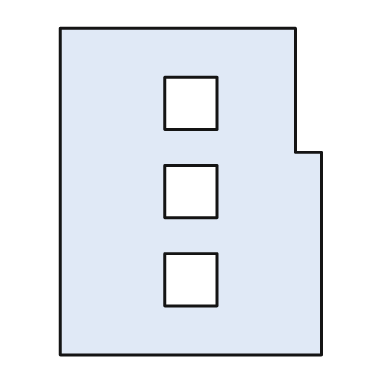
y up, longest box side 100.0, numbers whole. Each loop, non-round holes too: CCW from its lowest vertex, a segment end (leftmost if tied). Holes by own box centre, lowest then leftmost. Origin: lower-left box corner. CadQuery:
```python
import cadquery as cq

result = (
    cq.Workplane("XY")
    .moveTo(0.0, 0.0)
    .lineTo(80.0, 0.0)
    .lineTo(80.0, 62.0)
    .lineTo(72.0, 62.0)
    .lineTo(72.0, 100.0)
    .lineTo(0.0, 100.0)
    .close()
    .moveTo(32.0, 15.0)
    .lineTo(48.0, 15.0)
    .lineTo(48.0, 31.0)
    .lineTo(32.0, 31.0)
    .close()
    .moveTo(32.0, 42.0)
    .lineTo(48.0, 42.0)
    .lineTo(48.0, 58.0)
    .lineTo(32.0, 58.0)
    .close()
    .moveTo(32.0, 69.0)
    .lineTo(48.0, 69.0)
    .lineTo(48.0, 85.0)
    .lineTo(32.0, 85.0)
    .close()
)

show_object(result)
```